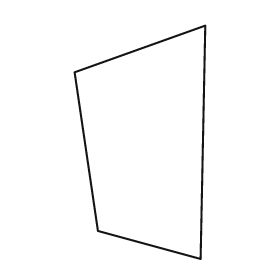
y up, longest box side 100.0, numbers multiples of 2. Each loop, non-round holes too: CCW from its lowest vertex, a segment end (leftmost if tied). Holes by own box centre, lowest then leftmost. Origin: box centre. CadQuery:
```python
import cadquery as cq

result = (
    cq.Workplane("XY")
    .moveTo(26.0, -50.0)
    .lineTo(28.0, 50.0)
    .lineTo(-28.0, 30.0)
    .lineTo(-18.0, -38.0)
    .close()
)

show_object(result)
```